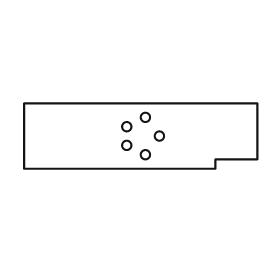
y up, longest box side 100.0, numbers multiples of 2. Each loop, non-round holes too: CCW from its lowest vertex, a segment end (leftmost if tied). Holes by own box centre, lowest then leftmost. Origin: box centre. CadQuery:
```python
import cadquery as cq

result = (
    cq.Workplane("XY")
    .moveTo(-50.0, -14.0)
    .lineTo(32.0, -14.0)
    .lineTo(32.0, -10.0)
    .lineTo(50.0, -10.0)
    .lineTo(50.0, 14.0)
    .lineTo(-50.0, 14.0)
    .close()
    .moveTo(2.0, -8.0)
    .circle(2.0)
    .moveTo(-6.0, -4.0)
    .circle(2.0)
    .moveTo(8.0, 0.0)
    .circle(2.0)
    .moveTo(-6.0, 4.0)
    .circle(2.0)
    .moveTo(2.0, 8.0)
    .circle(2.0)
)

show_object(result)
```